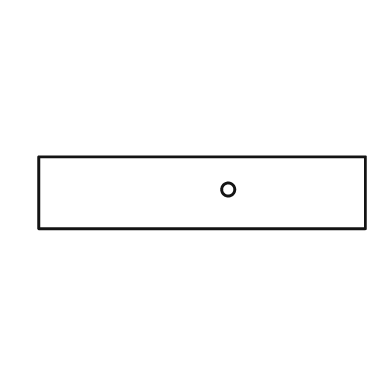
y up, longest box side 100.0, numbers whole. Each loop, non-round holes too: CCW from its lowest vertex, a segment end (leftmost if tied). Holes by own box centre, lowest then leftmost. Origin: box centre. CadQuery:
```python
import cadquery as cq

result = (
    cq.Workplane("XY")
    .moveTo(-50.0, -11.0)
    .lineTo(50.0, -11.0)
    .lineTo(50.0, 11.0)
    .lineTo(-50.0, 11.0)
    .close()
    .moveTo(8.0, 1.0)
    .circle(2.0)
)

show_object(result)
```